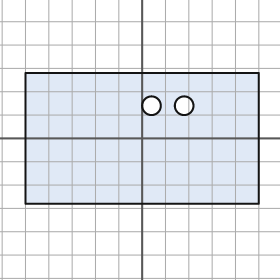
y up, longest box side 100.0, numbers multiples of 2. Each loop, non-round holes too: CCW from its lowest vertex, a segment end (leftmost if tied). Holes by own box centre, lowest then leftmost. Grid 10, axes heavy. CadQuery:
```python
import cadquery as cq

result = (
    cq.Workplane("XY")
    .moveTo(-50.0, -28.0)
    .lineTo(50.0, -28.0)
    .lineTo(50.0, 28.0)
    .lineTo(-50.0, 28.0)
    .close()
    .moveTo(4.0, 14.0)
    .circle(4.0)
    .moveTo(18.0, 14.0)
    .circle(4.0)
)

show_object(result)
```